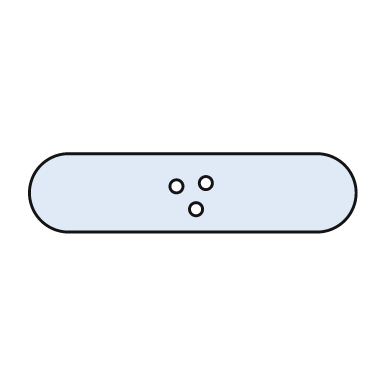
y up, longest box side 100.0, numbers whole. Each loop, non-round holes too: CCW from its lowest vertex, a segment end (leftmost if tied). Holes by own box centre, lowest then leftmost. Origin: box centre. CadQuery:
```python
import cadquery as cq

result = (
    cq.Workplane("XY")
    .moveTo(-38.0, -12.0)
    .lineTo(38.0, -12.0)
    .threePointArc((50.0, 0.0), (38.0, 12.0))
    .lineTo(-38.0, 12.0)
    .threePointArc((-50.0, 0.0), (-38.0, -12.0))
    .close()
    .moveTo(1.0, -5.0)
    .circle(2.0)
    .moveTo(-5.0, 2.0)
    .circle(2.0)
    .moveTo(4.0, 3.0)
    .circle(2.0)
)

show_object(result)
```